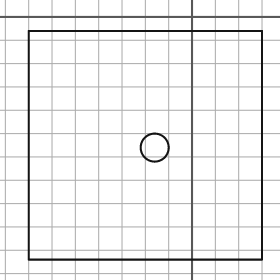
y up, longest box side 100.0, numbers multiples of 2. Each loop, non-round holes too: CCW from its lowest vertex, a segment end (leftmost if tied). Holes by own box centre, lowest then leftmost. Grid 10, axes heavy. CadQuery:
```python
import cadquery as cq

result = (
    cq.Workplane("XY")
    .moveTo(-70.0, -104.0)
    .lineTo(30.0, -104.0)
    .lineTo(30.0, -6.0)
    .lineTo(-70.0, -6.0)
    .close()
    .moveTo(-16.0, -56.0)
    .circle(6.0)
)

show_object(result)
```